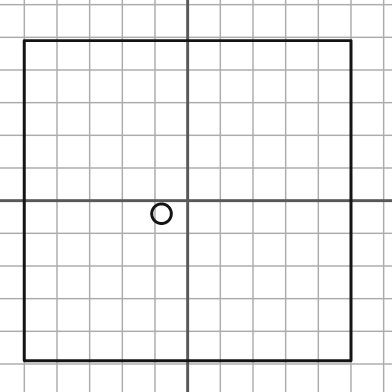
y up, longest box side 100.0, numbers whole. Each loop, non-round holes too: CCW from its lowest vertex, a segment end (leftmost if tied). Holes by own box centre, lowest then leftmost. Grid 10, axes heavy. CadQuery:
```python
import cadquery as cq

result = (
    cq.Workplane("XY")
    .moveTo(-50.0, -49.0)
    .lineTo(50.0, -49.0)
    .lineTo(50.0, 49.0)
    .lineTo(-50.0, 49.0)
    .close()
    .moveTo(-8.0, -4.0)
    .circle(3.0)
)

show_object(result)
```